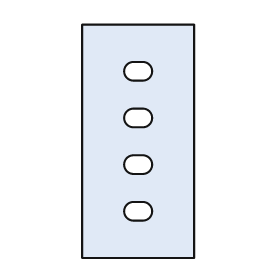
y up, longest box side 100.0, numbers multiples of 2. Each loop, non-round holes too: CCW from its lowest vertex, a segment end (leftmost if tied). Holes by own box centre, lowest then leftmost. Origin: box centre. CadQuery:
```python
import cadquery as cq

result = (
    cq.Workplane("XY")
    .moveTo(-24.0, -50.0)
    .lineTo(24.0, -50.0)
    .lineTo(24.0, 50.0)
    .lineTo(-24.0, 50.0)
    .close()
    .moveTo(-2.0, -34.0)
    .lineTo(2.0, -34.0)
    .threePointArc((6.0, -30.0), (2.0, -26.0))
    .lineTo(-2.0, -26.0)
    .threePointArc((-6.0, -30.0), (-2.0, -34.0))
    .close()
    .moveTo(-2.0, -14.0)
    .lineTo(2.0, -14.0)
    .threePointArc((6.0, -10.0), (2.0, -6.0))
    .lineTo(-2.0, -6.0)
    .threePointArc((-6.0, -10.0), (-2.0, -14.0))
    .close()
    .moveTo(-2.0, 6.0)
    .lineTo(2.0, 6.0)
    .threePointArc((6.0, 10.0), (2.0, 14.0))
    .lineTo(-2.0, 14.0)
    .threePointArc((-6.0, 10.0), (-2.0, 6.0))
    .close()
    .moveTo(-2.0, 26.0)
    .lineTo(2.0, 26.0)
    .threePointArc((6.0, 30.0), (2.0, 34.0))
    .lineTo(-2.0, 34.0)
    .threePointArc((-6.0, 30.0), (-2.0, 26.0))
    .close()
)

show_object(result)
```